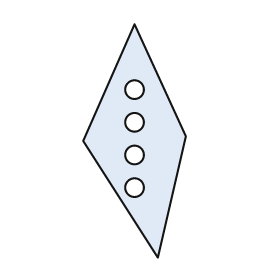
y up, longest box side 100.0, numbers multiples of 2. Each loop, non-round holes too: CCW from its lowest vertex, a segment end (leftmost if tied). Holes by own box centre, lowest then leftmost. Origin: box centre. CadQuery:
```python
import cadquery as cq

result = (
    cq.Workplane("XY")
    .moveTo(10.0, -50.0)
    .lineTo(22.0, 2.0)
    .lineTo(0.0, 50.0)
    .lineTo(-22.0, 0.0)
    .close()
    .moveTo(0.0, -20.0)
    .circle(4.0)
    .moveTo(0.0, -6.0)
    .circle(4.0)
    .moveTo(0.0, 8.0)
    .circle(4.0)
    .moveTo(0.0, 22.0)
    .circle(4.0)
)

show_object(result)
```